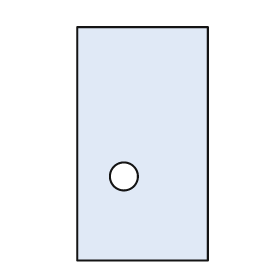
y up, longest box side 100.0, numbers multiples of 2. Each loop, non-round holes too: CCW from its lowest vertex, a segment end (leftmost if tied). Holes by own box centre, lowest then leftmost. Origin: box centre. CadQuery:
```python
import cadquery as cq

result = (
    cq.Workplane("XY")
    .moveTo(-28.0, -50.0)
    .lineTo(28.0, -50.0)
    .lineTo(28.0, 50.0)
    .lineTo(-28.0, 50.0)
    .close()
    .moveTo(-8.0, -14.0)
    .circle(6.0)
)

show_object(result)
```